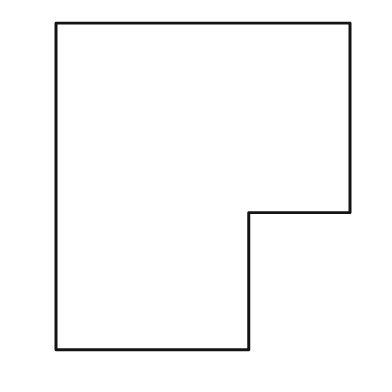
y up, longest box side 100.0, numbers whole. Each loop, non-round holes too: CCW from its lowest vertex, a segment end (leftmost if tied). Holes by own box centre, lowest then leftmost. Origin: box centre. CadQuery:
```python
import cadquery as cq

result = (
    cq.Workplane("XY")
    .moveTo(-45.0, -50.0)
    .lineTo(14.0, -50.0)
    .lineTo(14.0, -8.0)
    .lineTo(45.0, -8.0)
    .lineTo(45.0, 50.0)
    .lineTo(-45.0, 50.0)
    .close()
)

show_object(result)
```